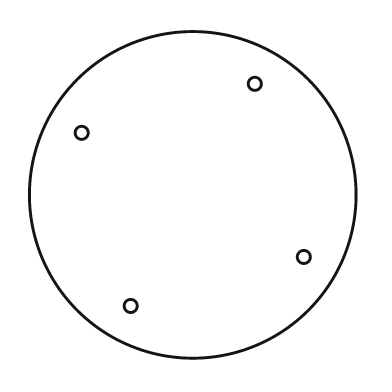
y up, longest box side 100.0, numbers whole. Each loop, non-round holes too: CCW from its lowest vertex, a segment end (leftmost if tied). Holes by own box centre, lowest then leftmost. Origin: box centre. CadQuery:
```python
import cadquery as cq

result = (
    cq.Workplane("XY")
    .moveTo(0.0, 0.0)
    .circle(50.0)
    .moveTo(-19.0, -34.0)
    .circle(2.0)
    .moveTo(34.0, -19.0)
    .circle(2.0)
    .moveTo(-34.0, 19.0)
    .circle(2.0)
    .moveTo(19.0, 34.0)
    .circle(2.0)
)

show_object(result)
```